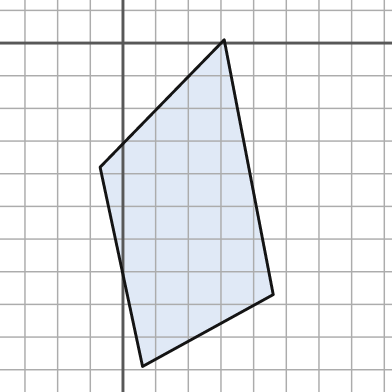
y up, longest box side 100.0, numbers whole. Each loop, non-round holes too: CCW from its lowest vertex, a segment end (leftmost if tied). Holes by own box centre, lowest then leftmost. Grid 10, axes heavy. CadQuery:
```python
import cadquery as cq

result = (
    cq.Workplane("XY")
    .moveTo(6.0, -99.0)
    .lineTo(46.0, -77.0)
    .lineTo(31.0, 1.0)
    .lineTo(-7.0, -38.0)
    .close()
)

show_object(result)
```